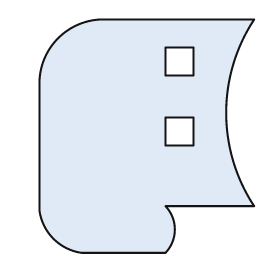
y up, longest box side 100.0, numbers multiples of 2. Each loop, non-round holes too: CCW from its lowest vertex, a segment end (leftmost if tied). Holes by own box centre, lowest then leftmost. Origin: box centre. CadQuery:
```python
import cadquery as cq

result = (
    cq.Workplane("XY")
    .moveTo(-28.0, -50.0)
    .lineTo(8.0, -50.0)
    .threePointArc((12.0, -40.0), (8.0, -30.0))
    .lineTo(46.0, -30.0)
    .threePointArc((34.0, 10.0), (46.0, 50.0))
    .lineTo(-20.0, 50.0)
    .threePointArc((-38.0, 42.0), (-46.0, 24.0))
    .lineTo(-46.0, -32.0)
    .threePointArc((-40.0, -44.0), (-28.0, -50.0))
    .close()
    .moveTo(8.0, -4.0)
    .lineTo(20.0, -4.0)
    .lineTo(20.0, 8.0)
    .lineTo(8.0, 8.0)
    .close()
    .moveTo(8.0, 26.0)
    .lineTo(20.0, 26.0)
    .lineTo(20.0, 38.0)
    .lineTo(8.0, 38.0)
    .close()
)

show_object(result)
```